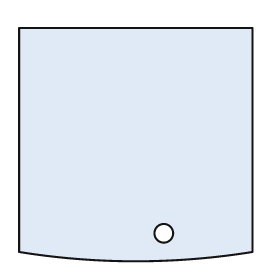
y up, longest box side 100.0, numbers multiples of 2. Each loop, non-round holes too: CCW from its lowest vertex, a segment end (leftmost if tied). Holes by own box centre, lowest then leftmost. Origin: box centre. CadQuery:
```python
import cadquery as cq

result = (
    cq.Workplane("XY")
    .moveTo(-50.0, -46.0)
    .threePointArc((0.0, -50.0), (50.0, -46.0))
    .lineTo(50.0, 50.0)
    .lineTo(-50.0, 50.0)
    .close()
    .moveTo(12.0, -38.0)
    .circle(4.0)
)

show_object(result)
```